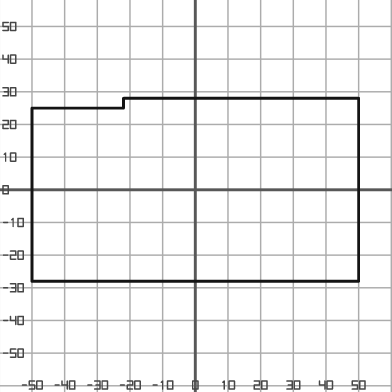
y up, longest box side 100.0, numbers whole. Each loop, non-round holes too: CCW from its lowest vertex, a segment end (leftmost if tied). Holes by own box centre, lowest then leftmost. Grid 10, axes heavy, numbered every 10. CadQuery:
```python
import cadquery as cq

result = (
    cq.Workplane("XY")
    .moveTo(-50.0, -28.0)
    .lineTo(50.0, -28.0)
    .lineTo(50.0, 28.0)
    .lineTo(-22.0, 28.0)
    .lineTo(-22.0, 25.0)
    .lineTo(-50.0, 25.0)
    .close()
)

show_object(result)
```